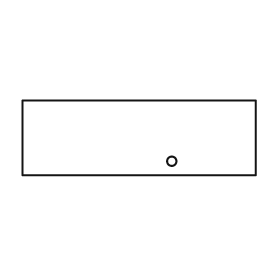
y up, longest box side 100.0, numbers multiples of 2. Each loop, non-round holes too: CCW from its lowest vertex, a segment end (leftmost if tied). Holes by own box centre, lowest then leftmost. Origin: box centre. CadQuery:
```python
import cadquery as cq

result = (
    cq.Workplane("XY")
    .moveTo(-50.0, -16.0)
    .lineTo(50.0, -16.0)
    .lineTo(50.0, 16.0)
    .lineTo(-50.0, 16.0)
    .close()
    .moveTo(14.0, -10.0)
    .circle(2.0)
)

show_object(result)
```